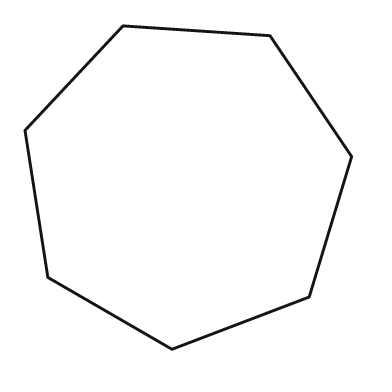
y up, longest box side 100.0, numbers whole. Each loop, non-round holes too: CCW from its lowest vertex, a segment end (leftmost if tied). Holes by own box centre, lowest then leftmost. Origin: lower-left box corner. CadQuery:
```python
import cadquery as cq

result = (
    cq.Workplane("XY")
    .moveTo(45.0, 0.0)
    .lineTo(87.0, 16.0)
    .lineTo(100.0, 59.0)
    .lineTo(75.0, 96.0)
    .lineTo(30.0, 99.0)
    .lineTo(0.0, 67.0)
    .lineTo(7.0, 22.0)
    .close()
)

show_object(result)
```